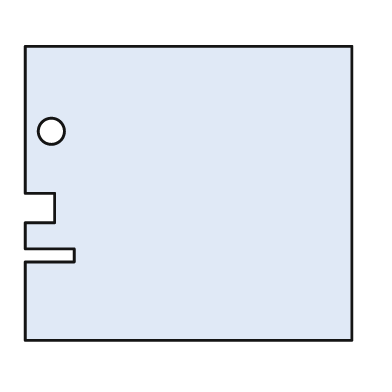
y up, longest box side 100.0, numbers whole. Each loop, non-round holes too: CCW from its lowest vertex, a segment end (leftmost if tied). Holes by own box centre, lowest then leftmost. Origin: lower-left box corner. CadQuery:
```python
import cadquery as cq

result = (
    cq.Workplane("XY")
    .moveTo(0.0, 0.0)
    .lineTo(100.0, 0.0)
    .lineTo(100.0, 90.0)
    .lineTo(0.0, 90.0)
    .lineTo(0.0, 45.0)
    .lineTo(9.0, 45.0)
    .lineTo(9.0, 36.0)
    .lineTo(0.0, 36.0)
    .lineTo(0.0, 28.0)
    .lineTo(15.0, 28.0)
    .lineTo(15.0, 24.0)
    .lineTo(0.0, 24.0)
    .close()
    .moveTo(8.0, 64.0)
    .circle(4.0)
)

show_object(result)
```